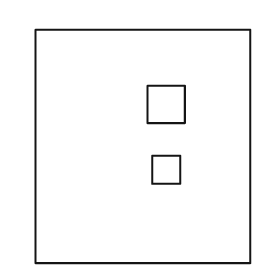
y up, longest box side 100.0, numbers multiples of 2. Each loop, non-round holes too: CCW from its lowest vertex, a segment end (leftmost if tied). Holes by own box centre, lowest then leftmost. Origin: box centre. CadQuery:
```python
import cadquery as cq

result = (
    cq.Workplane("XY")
    .moveTo(-46.0, -50.0)
    .lineTo(46.0, -50.0)
    .lineTo(46.0, 50.0)
    .lineTo(-46.0, 50.0)
    .close()
    .moveTo(4.0, -16.0)
    .lineTo(16.0, -16.0)
    .lineTo(16.0, -4.0)
    .lineTo(4.0, -4.0)
    .close()
    .moveTo(2.0, 10.0)
    .lineTo(18.0, 10.0)
    .lineTo(18.0, 26.0)
    .lineTo(2.0, 26.0)
    .close()
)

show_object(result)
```